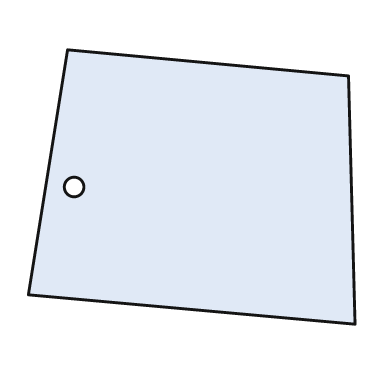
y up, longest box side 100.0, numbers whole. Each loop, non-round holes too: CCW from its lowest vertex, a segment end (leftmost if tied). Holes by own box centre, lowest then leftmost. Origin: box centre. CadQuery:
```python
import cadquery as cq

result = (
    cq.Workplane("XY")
    .moveTo(50.0, -42.0)
    .lineTo(48.0, 34.0)
    .lineTo(-38.0, 42.0)
    .lineTo(-50.0, -33.0)
    .close()
    .moveTo(-36.0, 0.0)
    .circle(3.0)
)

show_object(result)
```